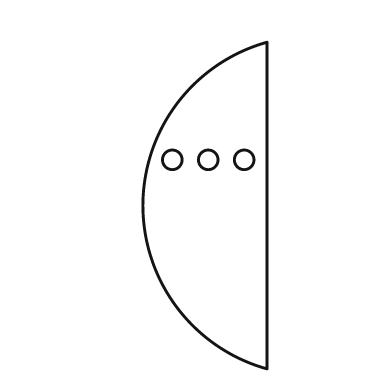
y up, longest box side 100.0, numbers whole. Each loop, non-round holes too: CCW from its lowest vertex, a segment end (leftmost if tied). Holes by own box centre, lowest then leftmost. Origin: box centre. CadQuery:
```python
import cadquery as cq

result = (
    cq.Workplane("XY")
    .moveTo(19.0, -50.0)
    .lineTo(19.0, 50.0)
    .threePointArc((-19.0, 0.0), (19.0, -50.0))
    .close()
    .moveTo(-10.0, 14.0)
    .circle(3.0)
    .moveTo(1.0, 14.0)
    .circle(3.0)
    .moveTo(12.0, 14.0)
    .circle(3.0)
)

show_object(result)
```